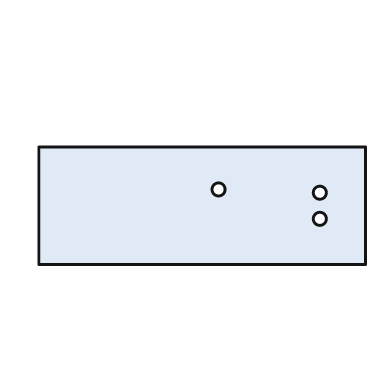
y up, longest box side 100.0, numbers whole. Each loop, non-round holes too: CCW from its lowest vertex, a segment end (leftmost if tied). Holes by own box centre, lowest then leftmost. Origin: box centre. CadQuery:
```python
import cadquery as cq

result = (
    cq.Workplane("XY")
    .moveTo(-50.0, -18.0)
    .lineTo(50.0, -18.0)
    .lineTo(50.0, 18.0)
    .lineTo(-50.0, 18.0)
    .close()
    .moveTo(36.0, -4.0)
    .circle(2.0)
    .moveTo(36.0, 4.0)
    .circle(2.0)
    .moveTo(5.0, 5.0)
    .circle(2.0)
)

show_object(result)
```